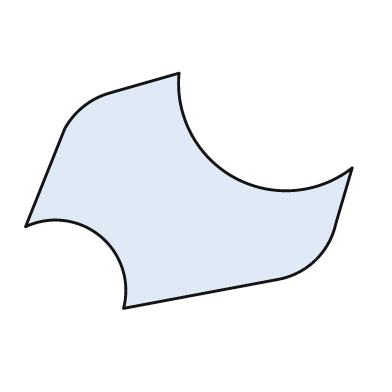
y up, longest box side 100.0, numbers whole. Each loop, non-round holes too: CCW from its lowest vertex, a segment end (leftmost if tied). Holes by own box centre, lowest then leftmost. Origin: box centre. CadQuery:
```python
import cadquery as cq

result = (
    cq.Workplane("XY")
    .moveTo(-20.0, -36.0)
    .lineTo(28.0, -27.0)
    .threePointArc((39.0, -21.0), (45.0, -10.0))
    .lineTo(50.0, 7.0)
    .threePointArc((14.0, 4.0), (-3.0, 36.0))
    .lineTo(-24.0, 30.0)
    .threePointArc((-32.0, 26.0), (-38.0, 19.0))
    .lineTo(-50.0, -11.0)
    .threePointArc((-27.0, -14.0), (-20.0, -36.0))
    .close()
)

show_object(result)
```